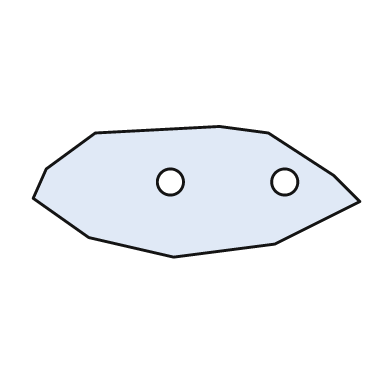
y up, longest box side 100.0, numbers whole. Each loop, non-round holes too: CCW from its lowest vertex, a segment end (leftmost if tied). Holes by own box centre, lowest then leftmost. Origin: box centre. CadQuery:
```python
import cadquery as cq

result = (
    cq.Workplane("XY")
    .moveTo(-7.0, -20.0)
    .lineTo(24.0, -16.0)
    .lineTo(50.0, -3.0)
    .lineTo(42.0, 5.0)
    .lineTo(22.0, 18.0)
    .lineTo(7.0, 20.0)
    .lineTo(-31.0, 18.0)
    .lineTo(-46.0, 7.0)
    .lineTo(-50.0, -2.0)
    .lineTo(-33.0, -14.0)
    .close()
    .moveTo(-8.0, 3.0)
    .circle(4.0)
    .moveTo(27.0, 3.0)
    .circle(4.0)
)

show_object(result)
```